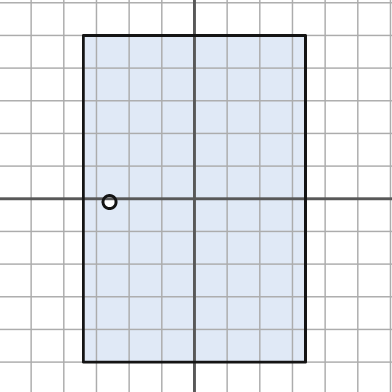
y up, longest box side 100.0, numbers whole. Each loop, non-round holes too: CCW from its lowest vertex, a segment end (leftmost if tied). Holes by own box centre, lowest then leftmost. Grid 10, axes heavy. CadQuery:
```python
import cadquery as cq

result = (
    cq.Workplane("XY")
    .moveTo(-34.0, -50.0)
    .lineTo(34.0, -50.0)
    .lineTo(34.0, 50.0)
    .lineTo(-34.0, 50.0)
    .close()
    .moveTo(-26.0, -1.0)
    .circle(2.0)
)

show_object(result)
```